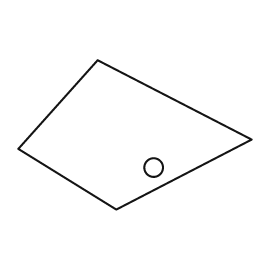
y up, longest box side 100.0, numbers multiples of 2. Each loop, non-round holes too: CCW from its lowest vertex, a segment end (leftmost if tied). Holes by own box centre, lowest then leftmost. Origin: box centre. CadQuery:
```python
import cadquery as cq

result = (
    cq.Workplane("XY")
    .moveTo(-8.0, -32.0)
    .lineTo(50.0, -2.0)
    .lineTo(-16.0, 32.0)
    .lineTo(-50.0, -6.0)
    .close()
    .moveTo(8.0, -14.0)
    .circle(4.0)
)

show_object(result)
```